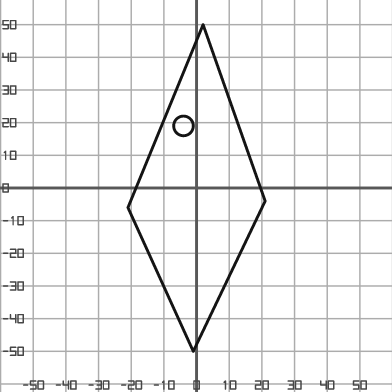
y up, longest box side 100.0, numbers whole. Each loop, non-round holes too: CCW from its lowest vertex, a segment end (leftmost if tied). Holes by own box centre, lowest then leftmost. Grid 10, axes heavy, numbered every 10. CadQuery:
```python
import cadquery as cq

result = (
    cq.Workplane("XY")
    .moveTo(-1.0, -50.0)
    .lineTo(21.0, -4.0)
    .lineTo(2.0, 50.0)
    .lineTo(-21.0, -6.0)
    .close()
    .moveTo(-4.0, 19.0)
    .circle(3.0)
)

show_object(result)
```